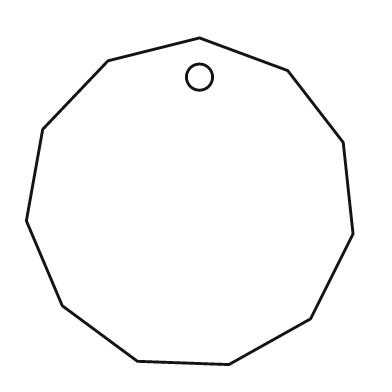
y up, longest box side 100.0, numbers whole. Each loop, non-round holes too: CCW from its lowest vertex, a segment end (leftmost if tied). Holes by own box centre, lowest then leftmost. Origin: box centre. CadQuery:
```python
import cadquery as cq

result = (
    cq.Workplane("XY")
    .moveTo(12.0, -50.0)
    .lineTo(37.0, -36.0)
    .lineTo(50.0, -10.0)
    .lineTo(47.0, 18.0)
    .lineTo(30.0, 40.0)
    .lineTo(3.0, 50.0)
    .lineTo(-25.0, 43.0)
    .lineTo(-45.0, 22.0)
    .lineTo(-50.0, -6.0)
    .lineTo(-39.0, -32.0)
    .lineTo(-16.0, -49.0)
    .close()
    .moveTo(3.0, 38.0)
    .circle(4.0)
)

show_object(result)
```